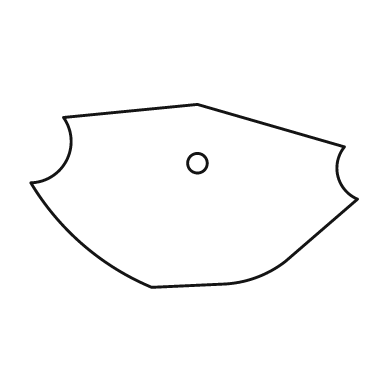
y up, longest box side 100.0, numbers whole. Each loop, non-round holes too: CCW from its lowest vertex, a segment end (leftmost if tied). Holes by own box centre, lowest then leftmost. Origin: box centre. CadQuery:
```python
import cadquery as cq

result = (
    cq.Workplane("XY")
    .moveTo(-13.0, -28.0)
    .lineTo(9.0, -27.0)
    .threePointArc((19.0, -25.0), (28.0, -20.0))
    .lineTo(50.0, -1.0)
    .threePointArc((44.0, 6.0), (46.0, 15.0))
    .lineTo(1.0, 28.0)
    .lineTo(-40.0, 24.0)
    .threePointArc((-39.0, 11.0), (-50.0, 4.0))
    .threePointArc((-34.0, -15.0), (-13.0, -28.0))
    .close()
    .moveTo(1.0, 10.0)
    .circle(3.0)
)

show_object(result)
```